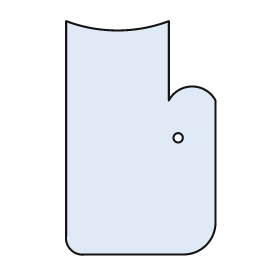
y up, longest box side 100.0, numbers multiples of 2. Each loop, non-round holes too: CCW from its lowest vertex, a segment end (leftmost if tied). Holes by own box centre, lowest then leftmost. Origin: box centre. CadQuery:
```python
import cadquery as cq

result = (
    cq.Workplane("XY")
    .moveTo(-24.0, -50.0)
    .lineTo(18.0, -50.0)
    .threePointArc((28.0, -46.0), (32.0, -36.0))
    .lineTo(32.0, 16.0)
    .threePointArc((22.0, 22.0), (12.0, 16.0))
    .lineTo(12.0, 50.0)
    .threePointArc((-10.0, 46.0), (-32.0, 50.0))
    .lineTo(-32.0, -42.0)
    .threePointArc((-30.0, -48.0), (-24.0, -50.0))
    .close()
    .moveTo(16.0, 0.0)
    .circle(2.0)
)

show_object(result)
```